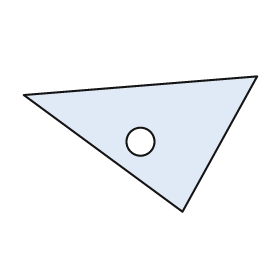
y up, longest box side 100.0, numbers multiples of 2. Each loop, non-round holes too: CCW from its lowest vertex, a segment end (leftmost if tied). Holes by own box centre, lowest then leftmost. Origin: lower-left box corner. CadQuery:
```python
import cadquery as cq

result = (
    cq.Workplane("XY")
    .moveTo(68.0, 0.0)
    .lineTo(100.0, 58.0)
    .lineTo(0.0, 50.0)
    .close()
    .moveTo(50.0, 30.0)
    .circle(6.0)
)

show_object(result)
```